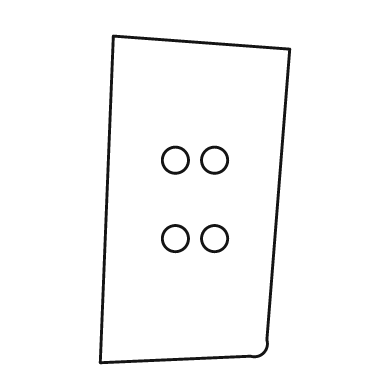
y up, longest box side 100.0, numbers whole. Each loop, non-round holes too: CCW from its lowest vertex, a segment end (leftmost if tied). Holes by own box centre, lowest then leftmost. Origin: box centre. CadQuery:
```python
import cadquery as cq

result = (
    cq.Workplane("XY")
    .moveTo(-29.0, -50.0)
    .lineTo(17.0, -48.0)
    .threePointArc((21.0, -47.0), (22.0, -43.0))
    .lineTo(29.0, 46.0)
    .lineTo(-25.0, 50.0)
    .close()
    .moveTo(-6.0, -12.0)
    .circle(4.0)
    .moveTo(6.0, -12.0)
    .circle(4.0)
    .moveTo(-6.0, 12.0)
    .circle(4.0)
    .moveTo(6.0, 12.0)
    .circle(4.0)
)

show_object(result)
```